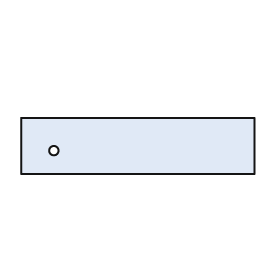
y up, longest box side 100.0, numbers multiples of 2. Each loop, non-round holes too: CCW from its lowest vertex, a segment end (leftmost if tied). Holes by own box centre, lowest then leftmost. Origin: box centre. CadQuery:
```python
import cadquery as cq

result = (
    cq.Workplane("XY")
    .moveTo(-50.0, -12.0)
    .lineTo(50.0, -12.0)
    .lineTo(50.0, 12.0)
    .lineTo(-50.0, 12.0)
    .close()
    .moveTo(-36.0, -2.0)
    .circle(2.0)
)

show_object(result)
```